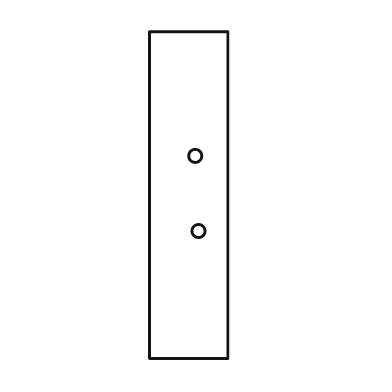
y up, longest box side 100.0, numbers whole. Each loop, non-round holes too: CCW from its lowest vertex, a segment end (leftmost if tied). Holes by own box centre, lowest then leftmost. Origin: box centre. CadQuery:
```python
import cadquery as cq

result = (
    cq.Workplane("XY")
    .moveTo(-12.0, -50.0)
    .lineTo(12.0, -50.0)
    .lineTo(12.0, 50.0)
    .lineTo(-12.0, 50.0)
    .close()
    .moveTo(3.0, -11.0)
    .circle(2.0)
    .moveTo(2.0, 12.0)
    .circle(2.0)
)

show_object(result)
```